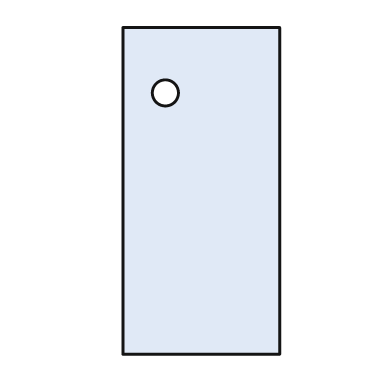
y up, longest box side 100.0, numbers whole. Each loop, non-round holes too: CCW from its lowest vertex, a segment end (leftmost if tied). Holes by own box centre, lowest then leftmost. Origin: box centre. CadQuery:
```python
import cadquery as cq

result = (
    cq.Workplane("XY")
    .moveTo(-24.0, -50.0)
    .lineTo(24.0, -50.0)
    .lineTo(24.0, 50.0)
    .lineTo(-24.0, 50.0)
    .close()
    .moveTo(-11.0, 30.0)
    .circle(4.0)
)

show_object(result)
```